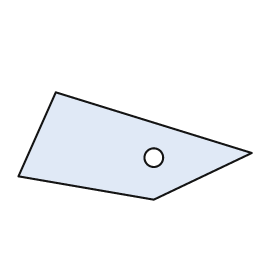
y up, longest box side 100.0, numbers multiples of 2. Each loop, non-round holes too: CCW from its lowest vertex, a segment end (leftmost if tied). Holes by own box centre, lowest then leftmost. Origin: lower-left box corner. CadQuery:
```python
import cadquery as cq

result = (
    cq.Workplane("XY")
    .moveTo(58.0, 0.0)
    .lineTo(100.0, 20.0)
    .lineTo(16.0, 46.0)
    .lineTo(0.0, 10.0)
    .close()
    .moveTo(58.0, 18.0)
    .circle(4.0)
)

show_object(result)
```